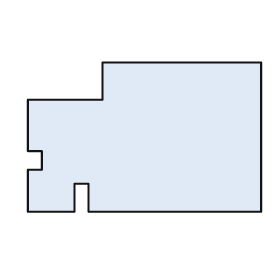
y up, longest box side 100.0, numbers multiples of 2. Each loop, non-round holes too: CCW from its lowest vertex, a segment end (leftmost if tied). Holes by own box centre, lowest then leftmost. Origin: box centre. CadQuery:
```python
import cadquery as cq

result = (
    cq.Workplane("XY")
    .moveTo(-50.0, -32.0)
    .lineTo(-30.0, -32.0)
    .lineTo(-30.0, -20.0)
    .lineTo(-24.0, -20.0)
    .lineTo(-24.0, -32.0)
    .lineTo(50.0, -32.0)
    .lineTo(50.0, 32.0)
    .lineTo(-18.0, 32.0)
    .lineTo(-18.0, 16.0)
    .lineTo(-50.0, 16.0)
    .lineTo(-50.0, -6.0)
    .lineTo(-44.0, -6.0)
    .lineTo(-44.0, -14.0)
    .lineTo(-50.0, -14.0)
    .close()
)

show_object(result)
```